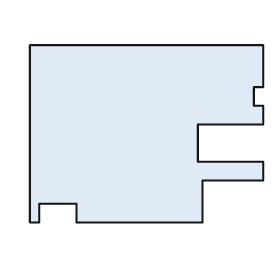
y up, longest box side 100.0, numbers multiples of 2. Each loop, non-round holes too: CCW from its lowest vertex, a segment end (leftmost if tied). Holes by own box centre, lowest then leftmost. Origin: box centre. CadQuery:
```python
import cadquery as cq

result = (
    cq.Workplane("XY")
    .moveTo(-50.0, -38.0)
    .lineTo(-46.0, -38.0)
    .lineTo(-46.0, -30.0)
    .lineTo(-30.0, -30.0)
    .lineTo(-30.0, -38.0)
    .lineTo(24.0, -38.0)
    .lineTo(24.0, -20.0)
    .lineTo(50.0, -20.0)
    .lineTo(50.0, -12.0)
    .lineTo(22.0, -12.0)
    .lineTo(22.0, 4.0)
    .lineTo(50.0, 4.0)
    .lineTo(50.0, 12.0)
    .lineTo(46.0, 12.0)
    .lineTo(46.0, 20.0)
    .lineTo(50.0, 20.0)
    .lineTo(50.0, 38.0)
    .lineTo(-50.0, 38.0)
    .close()
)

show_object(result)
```